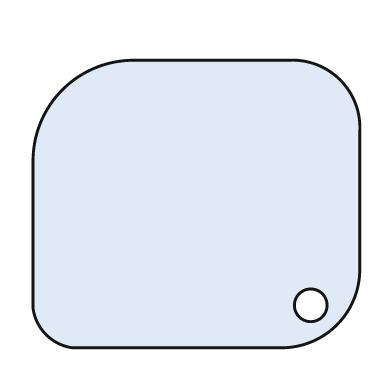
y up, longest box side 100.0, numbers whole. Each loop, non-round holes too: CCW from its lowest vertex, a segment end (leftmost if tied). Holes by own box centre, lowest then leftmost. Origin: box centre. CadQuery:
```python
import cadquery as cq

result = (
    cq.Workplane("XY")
    .moveTo(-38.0, -44.0)
    .lineTo(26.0, -44.0)
    .threePointArc((43.0, -37.0), (50.0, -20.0))
    .lineTo(50.0, 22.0)
    .threePointArc((44.0, 38.0), (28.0, 44.0))
    .lineTo(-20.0, 44.0)
    .threePointArc((-41.0, 35.0), (-50.0, 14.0))
    .lineTo(-50.0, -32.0)
    .threePointArc((-46.0, -40.0), (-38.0, -44.0))
    .close()
    .moveTo(35.0, -31.0)
    .circle(5.0)
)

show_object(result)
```